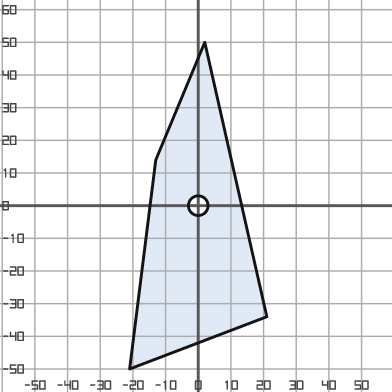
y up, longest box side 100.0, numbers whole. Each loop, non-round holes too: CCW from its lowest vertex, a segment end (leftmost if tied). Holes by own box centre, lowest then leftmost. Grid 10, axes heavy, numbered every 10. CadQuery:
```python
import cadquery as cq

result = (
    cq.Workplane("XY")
    .moveTo(-21.0, -50.0)
    .lineTo(21.0, -34.0)
    .lineTo(2.0, 50.0)
    .lineTo(-13.0, 14.0)
    .close()
    .moveTo(0.0, 0.0)
    .circle(3.0)
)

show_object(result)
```